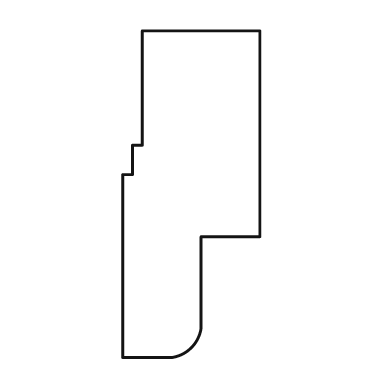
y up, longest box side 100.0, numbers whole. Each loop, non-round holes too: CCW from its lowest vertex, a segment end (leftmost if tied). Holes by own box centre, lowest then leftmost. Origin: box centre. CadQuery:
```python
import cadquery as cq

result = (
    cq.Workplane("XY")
    .moveTo(-21.0, -50.0)
    .lineTo(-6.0, -50.0)
    .threePointArc((0.0, -47.0), (3.0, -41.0))
    .lineTo(3.0, -13.0)
    .lineTo(21.0, -13.0)
    .lineTo(21.0, 50.0)
    .lineTo(-15.0, 50.0)
    .lineTo(-15.0, 15.0)
    .lineTo(-18.0, 15.0)
    .lineTo(-18.0, 6.0)
    .lineTo(-21.0, 6.0)
    .close()
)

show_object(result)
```